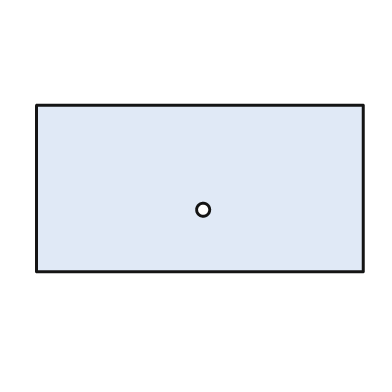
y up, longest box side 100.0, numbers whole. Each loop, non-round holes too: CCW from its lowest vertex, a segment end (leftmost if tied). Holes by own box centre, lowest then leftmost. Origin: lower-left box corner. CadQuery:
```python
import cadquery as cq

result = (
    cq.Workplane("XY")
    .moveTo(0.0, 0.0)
    .lineTo(100.0, 0.0)
    .lineTo(100.0, 51.0)
    .lineTo(0.0, 51.0)
    .close()
    .moveTo(51.0, 19.0)
    .circle(2.0)
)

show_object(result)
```